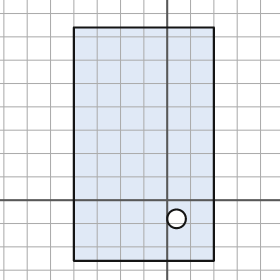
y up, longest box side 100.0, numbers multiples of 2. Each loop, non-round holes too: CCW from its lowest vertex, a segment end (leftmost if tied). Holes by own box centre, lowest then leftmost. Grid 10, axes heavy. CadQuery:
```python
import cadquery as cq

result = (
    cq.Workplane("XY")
    .moveTo(-40.0, -26.0)
    .lineTo(20.0, -26.0)
    .lineTo(20.0, 74.0)
    .lineTo(-40.0, 74.0)
    .close()
    .moveTo(4.0, -8.0)
    .circle(4.0)
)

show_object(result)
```